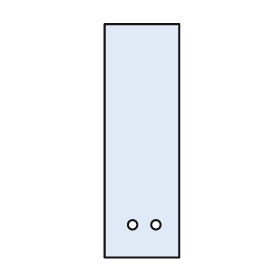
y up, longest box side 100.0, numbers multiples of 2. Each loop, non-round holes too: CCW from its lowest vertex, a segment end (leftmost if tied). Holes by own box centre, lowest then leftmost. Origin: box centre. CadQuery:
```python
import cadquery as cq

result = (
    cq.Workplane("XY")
    .moveTo(-16.0, -50.0)
    .lineTo(16.0, -50.0)
    .lineTo(16.0, 50.0)
    .lineTo(-16.0, 50.0)
    .close()
    .moveTo(-4.0, -36.0)
    .circle(2.0)
    .moveTo(6.0, -36.0)
    .circle(2.0)
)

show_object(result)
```